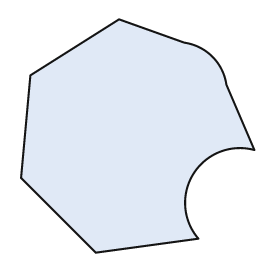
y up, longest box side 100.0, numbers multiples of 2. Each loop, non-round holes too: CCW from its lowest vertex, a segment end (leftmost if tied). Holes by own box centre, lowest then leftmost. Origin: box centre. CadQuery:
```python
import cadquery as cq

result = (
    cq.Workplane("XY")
    .moveTo(-18.0, -50.0)
    .lineTo(26.0, -44.0)
    .threePointArc((24.0, -16.0), (50.0, -6.0))
    .lineTo(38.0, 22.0)
    .threePointArc((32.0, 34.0), (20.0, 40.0))
    .lineTo(-8.0, 50.0)
    .lineTo(-46.0, 26.0)
    .lineTo(-50.0, -18.0)
    .close()
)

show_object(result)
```